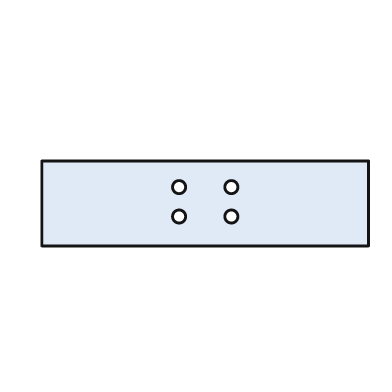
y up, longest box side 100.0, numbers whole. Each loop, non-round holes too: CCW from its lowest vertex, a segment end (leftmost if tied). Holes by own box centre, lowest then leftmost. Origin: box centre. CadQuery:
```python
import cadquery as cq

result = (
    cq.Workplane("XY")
    .moveTo(-50.0, -13.0)
    .lineTo(50.0, -13.0)
    .lineTo(50.0, 13.0)
    .lineTo(-50.0, 13.0)
    .close()
    .moveTo(-8.0, -4.0)
    .circle(2.0)
    .moveTo(8.0, -4.0)
    .circle(2.0)
    .moveTo(-8.0, 5.0)
    .circle(2.0)
    .moveTo(8.0, 5.0)
    .circle(2.0)
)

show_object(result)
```